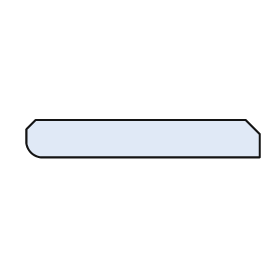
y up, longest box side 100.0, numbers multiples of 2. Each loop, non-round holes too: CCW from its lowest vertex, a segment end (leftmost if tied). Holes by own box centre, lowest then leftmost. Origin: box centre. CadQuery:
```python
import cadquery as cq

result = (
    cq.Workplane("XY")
    .moveTo(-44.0, -8.0)
    .lineTo(50.0, -8.0)
    .lineTo(50.0, 2.0)
    .lineTo(44.0, 8.0)
    .lineTo(-46.0, 8.0)
    .lineTo(-50.0, 4.0)
    .lineTo(-50.0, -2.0)
    .threePointArc((-48.0, -6.0), (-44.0, -8.0))
    .close()
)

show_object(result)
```